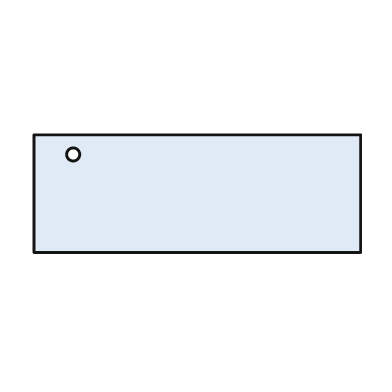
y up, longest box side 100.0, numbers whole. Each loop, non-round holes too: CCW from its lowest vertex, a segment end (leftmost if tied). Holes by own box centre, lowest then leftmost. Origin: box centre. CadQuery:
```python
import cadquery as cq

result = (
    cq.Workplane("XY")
    .moveTo(-50.0, -18.0)
    .lineTo(50.0, -18.0)
    .lineTo(50.0, 18.0)
    .lineTo(-50.0, 18.0)
    .close()
    .moveTo(-38.0, 12.0)
    .circle(2.0)
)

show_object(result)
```